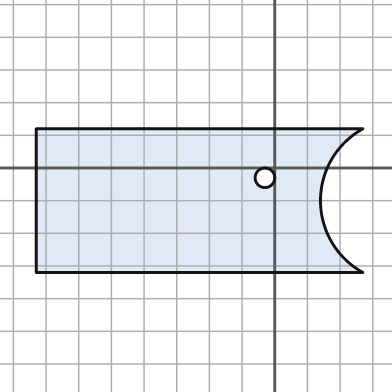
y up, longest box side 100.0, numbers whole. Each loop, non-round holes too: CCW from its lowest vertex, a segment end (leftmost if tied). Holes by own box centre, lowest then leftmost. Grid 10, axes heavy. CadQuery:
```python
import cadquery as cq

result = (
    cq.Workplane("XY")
    .moveTo(-73.0, -32.0)
    .lineTo(27.0, -32.0)
    .threePointArc((14.0, -10.0), (27.0, 12.0))
    .lineTo(-73.0, 12.0)
    .close()
    .moveTo(-3.0, -3.0)
    .circle(3.0)
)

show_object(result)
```